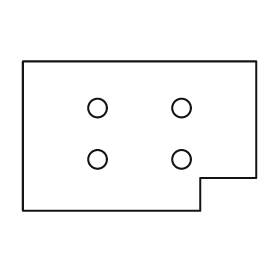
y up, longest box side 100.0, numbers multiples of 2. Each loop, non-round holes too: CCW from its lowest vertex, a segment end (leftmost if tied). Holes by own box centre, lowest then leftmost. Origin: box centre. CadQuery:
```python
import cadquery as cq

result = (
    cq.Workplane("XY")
    .moveTo(-50.0, -32.0)
    .lineTo(26.0, -32.0)
    .lineTo(26.0, -18.0)
    .lineTo(50.0, -18.0)
    .lineTo(50.0, 32.0)
    .lineTo(-50.0, 32.0)
    .close()
    .moveTo(-18.0, -10.0)
    .circle(4.0)
    .moveTo(18.0, -10.0)
    .circle(4.0)
    .moveTo(-18.0, 12.0)
    .circle(4.0)
    .moveTo(18.0, 12.0)
    .circle(4.0)
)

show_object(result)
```